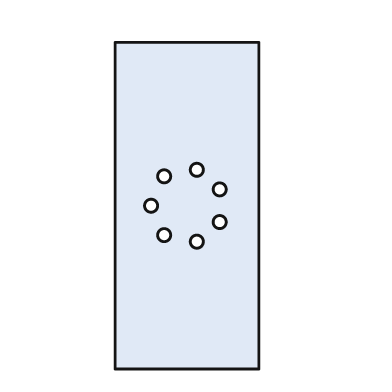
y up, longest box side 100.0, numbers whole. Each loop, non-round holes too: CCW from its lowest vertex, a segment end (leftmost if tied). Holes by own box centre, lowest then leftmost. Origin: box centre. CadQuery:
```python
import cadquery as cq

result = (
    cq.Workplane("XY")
    .moveTo(-22.0, -50.0)
    .lineTo(22.0, -50.0)
    .lineTo(22.0, 50.0)
    .lineTo(-22.0, 50.0)
    .close()
    .moveTo(3.0, -11.0)
    .circle(2.0)
    .moveTo(-7.0, -9.0)
    .circle(2.0)
    .moveTo(10.0, -5.0)
    .circle(2.0)
    .moveTo(-11.0, 0.0)
    .circle(2.0)
    .moveTo(10.0, 5.0)
    .circle(2.0)
    .moveTo(-7.0, 9.0)
    .circle(2.0)
    .moveTo(3.0, 11.0)
    .circle(2.0)
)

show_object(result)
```